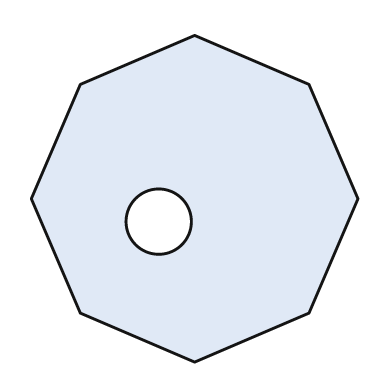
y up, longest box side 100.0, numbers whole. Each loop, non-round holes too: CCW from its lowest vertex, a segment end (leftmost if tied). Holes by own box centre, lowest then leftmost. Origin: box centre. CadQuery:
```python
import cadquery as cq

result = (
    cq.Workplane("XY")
    .moveTo(0.0, -50.0)
    .lineTo(35.0, -35.0)
    .lineTo(50.0, 0.0)
    .lineTo(35.0, 35.0)
    .lineTo(0.0, 50.0)
    .lineTo(-35.0, 35.0)
    .lineTo(-50.0, 0.0)
    .lineTo(-35.0, -35.0)
    .close()
    .moveTo(-11.0, -7.0)
    .circle(10.0)
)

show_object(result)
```